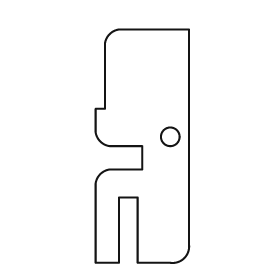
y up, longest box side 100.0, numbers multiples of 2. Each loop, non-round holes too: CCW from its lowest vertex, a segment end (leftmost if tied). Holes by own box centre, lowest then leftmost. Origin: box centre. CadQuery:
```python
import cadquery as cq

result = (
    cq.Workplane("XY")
    .moveTo(-20.0, -50.0)
    .lineTo(-10.0, -50.0)
    .lineTo(-10.0, -22.0)
    .lineTo(-2.0, -22.0)
    .lineTo(-2.0, -50.0)
    .lineTo(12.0, -50.0)
    .threePointArc((18.0, -48.0), (20.0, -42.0))
    .lineTo(20.0, 50.0)
    .lineTo(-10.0, 50.0)
    .threePointArc((-14.0, 48.0), (-16.0, 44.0))
    .lineTo(-16.0, 16.0)
    .lineTo(-20.0, 16.0)
    .lineTo(-20.0, 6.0)
    .threePointArc((-18.0, 2.0), (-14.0, 0.0))
    .lineTo(0.0, 0.0)
    .lineTo(0.0, -10.0)
    .lineTo(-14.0, -10.0)
    .threePointArc((-18.0, -12.0), (-20.0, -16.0))
    .close()
    .moveTo(12.0, 4.0)
    .circle(4.0)
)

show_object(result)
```